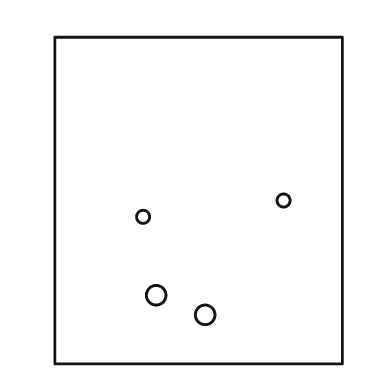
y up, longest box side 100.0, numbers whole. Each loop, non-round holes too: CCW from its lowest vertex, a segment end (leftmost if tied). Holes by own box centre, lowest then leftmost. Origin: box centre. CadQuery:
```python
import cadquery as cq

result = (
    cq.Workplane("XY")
    .moveTo(-44.0, -50.0)
    .lineTo(44.0, -50.0)
    .lineTo(44.0, 50.0)
    .lineTo(-44.0, 50.0)
    .close()
    .moveTo(2.0, -35.0)
    .circle(3.0)
    .moveTo(-13.0, -29.0)
    .circle(3.0)
    .moveTo(-17.0, -5.0)
    .circle(2.0)
    .moveTo(26.0, 0.0)
    .circle(2.0)
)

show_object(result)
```